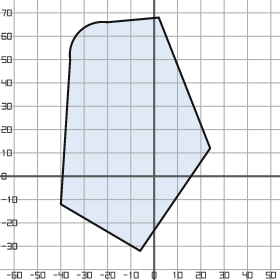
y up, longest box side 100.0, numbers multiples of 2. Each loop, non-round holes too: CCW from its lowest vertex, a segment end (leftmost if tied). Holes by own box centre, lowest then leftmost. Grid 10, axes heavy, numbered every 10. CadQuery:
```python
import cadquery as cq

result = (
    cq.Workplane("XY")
    .moveTo(-6.0, -32.0)
    .lineTo(24.0, 12.0)
    .lineTo(2.0, 68.0)
    .lineTo(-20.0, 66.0)
    .threePointArc((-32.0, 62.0), (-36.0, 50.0))
    .lineTo(-40.0, -12.0)
    .close()
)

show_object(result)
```